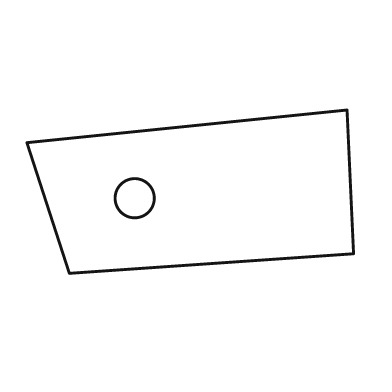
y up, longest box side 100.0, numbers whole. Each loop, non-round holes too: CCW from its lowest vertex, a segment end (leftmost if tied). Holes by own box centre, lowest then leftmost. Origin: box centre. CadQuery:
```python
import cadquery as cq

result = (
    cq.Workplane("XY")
    .moveTo(-37.0, -25.0)
    .lineTo(50.0, -19.0)
    .lineTo(48.0, 25.0)
    .lineTo(-50.0, 15.0)
    .close()
    .moveTo(-17.0, -2.0)
    .circle(6.0)
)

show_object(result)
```